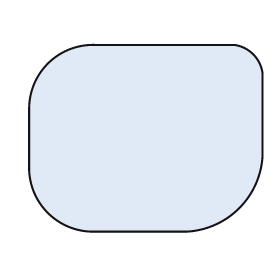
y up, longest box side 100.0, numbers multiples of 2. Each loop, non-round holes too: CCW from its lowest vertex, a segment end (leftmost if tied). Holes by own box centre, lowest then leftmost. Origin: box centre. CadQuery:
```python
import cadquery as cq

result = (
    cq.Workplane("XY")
    .moveTo(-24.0, -40.0)
    .lineTo(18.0, -40.0)
    .threePointArc((40.0, -30.0), (50.0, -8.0))
    .lineTo(50.0, 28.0)
    .threePointArc((46.0, 36.0), (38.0, 40.0))
    .lineTo(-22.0, 40.0)
    .threePointArc((-42.0, 32.0), (-50.0, 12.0))
    .lineTo(-50.0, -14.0)
    .threePointArc((-42.0, -32.0), (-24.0, -40.0))
    .close()
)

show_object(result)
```